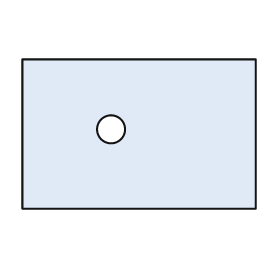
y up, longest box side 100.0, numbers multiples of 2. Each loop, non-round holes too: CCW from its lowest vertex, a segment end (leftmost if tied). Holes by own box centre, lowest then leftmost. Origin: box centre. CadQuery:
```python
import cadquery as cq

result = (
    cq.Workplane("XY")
    .moveTo(-50.0, -32.0)
    .lineTo(50.0, -32.0)
    .lineTo(50.0, 32.0)
    .lineTo(-50.0, 32.0)
    .close()
    .moveTo(-12.0, 2.0)
    .circle(6.0)
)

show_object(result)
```